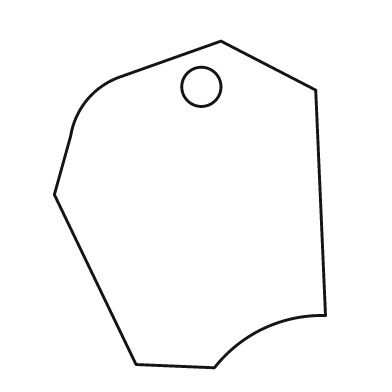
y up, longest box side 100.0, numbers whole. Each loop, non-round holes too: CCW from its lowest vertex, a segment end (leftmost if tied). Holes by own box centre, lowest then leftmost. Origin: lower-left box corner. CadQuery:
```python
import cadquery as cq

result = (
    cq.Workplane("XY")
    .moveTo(49.0, 0.0)
    .threePointArc((64.0, 12.0), (83.0, 16.0))
    .lineTo(80.0, 85.0)
    .lineTo(51.0, 100.0)
    .lineTo(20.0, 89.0)
    .threePointArc((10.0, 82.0), (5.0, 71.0))
    .lineTo(0.0, 53.0)
    .lineTo(25.0, 1.0)
    .close()
    .moveTo(45.0, 86.0)
    .circle(6.0)
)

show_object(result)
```